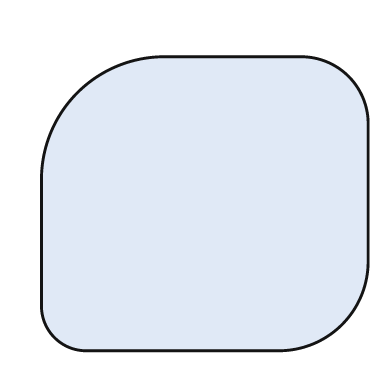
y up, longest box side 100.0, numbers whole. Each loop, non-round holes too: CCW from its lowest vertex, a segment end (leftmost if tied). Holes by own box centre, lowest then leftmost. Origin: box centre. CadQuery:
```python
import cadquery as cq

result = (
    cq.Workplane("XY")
    .moveTo(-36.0, -45.0)
    .lineTo(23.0, -45.0)
    .threePointArc((42.0, -37.0), (50.0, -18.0))
    .lineTo(50.0, 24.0)
    .threePointArc((44.0, 39.0), (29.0, 45.0))
    .lineTo(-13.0, 45.0)
    .threePointArc((-39.0, 34.0), (-50.0, 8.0))
    .lineTo(-50.0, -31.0)
    .threePointArc((-46.0, -41.0), (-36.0, -45.0))
    .close()
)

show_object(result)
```